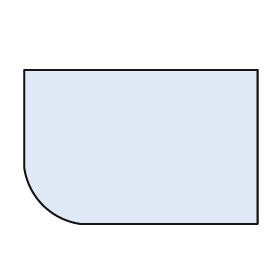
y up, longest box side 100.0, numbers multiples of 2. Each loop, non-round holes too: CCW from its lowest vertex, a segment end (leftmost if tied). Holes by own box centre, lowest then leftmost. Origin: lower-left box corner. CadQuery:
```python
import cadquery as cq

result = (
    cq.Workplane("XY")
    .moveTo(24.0, 0.0)
    .lineTo(100.0, 0.0)
    .lineTo(100.0, 66.0)
    .lineTo(0.0, 66.0)
    .lineTo(0.0, 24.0)
    .threePointArc((8.0, 8.0), (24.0, 0.0))
    .close()
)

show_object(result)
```